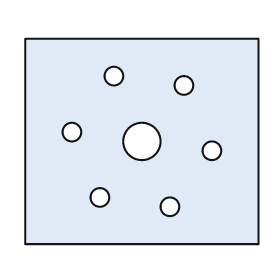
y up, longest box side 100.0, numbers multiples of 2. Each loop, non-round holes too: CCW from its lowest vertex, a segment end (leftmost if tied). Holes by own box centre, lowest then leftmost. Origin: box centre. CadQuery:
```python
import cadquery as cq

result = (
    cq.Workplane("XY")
    .moveTo(-50.0, -44.0)
    .lineTo(50.0, -44.0)
    .lineTo(50.0, 44.0)
    .lineTo(-50.0, 44.0)
    .close()
    .moveTo(12.0, -28.0)
    .circle(4.0)
    .moveTo(-18.0, -24.0)
    .circle(4.0)
    .moveTo(30.0, -4.0)
    .circle(4.0)
    .moveTo(0.0, 0.0)
    .circle(8.0)
    .moveTo(-30.0, 4.0)
    .circle(4.0)
    .moveTo(18.0, 24.0)
    .circle(4.0)
    .moveTo(-12.0, 28.0)
    .circle(4.0)
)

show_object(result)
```